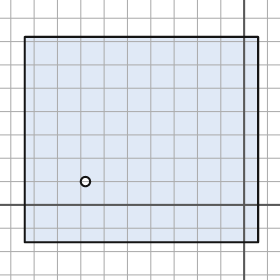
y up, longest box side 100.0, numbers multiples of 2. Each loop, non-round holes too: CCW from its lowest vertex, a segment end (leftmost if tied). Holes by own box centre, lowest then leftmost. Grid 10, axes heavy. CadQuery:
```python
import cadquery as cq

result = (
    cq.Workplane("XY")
    .moveTo(-94.0, -16.0)
    .lineTo(6.0, -16.0)
    .lineTo(6.0, 72.0)
    .lineTo(-94.0, 72.0)
    .close()
    .moveTo(-68.0, 10.0)
    .circle(2.0)
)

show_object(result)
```